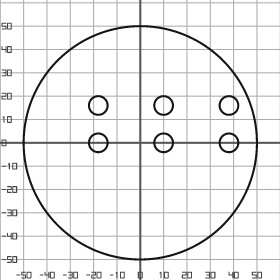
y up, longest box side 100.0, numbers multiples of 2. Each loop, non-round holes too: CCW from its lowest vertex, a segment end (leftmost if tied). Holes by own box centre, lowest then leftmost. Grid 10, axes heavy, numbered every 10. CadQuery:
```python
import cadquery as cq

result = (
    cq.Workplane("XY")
    .moveTo(0.0, 0.0)
    .circle(50.0)
    .moveTo(-18.0, 0.0)
    .circle(4.0)
    .moveTo(10.0, 0.0)
    .circle(4.0)
    .moveTo(38.0, 0.0)
    .circle(4.0)
    .moveTo(-18.0, 16.0)
    .circle(4.0)
    .moveTo(10.0, 16.0)
    .circle(4.0)
    .moveTo(38.0, 16.0)
    .circle(4.0)
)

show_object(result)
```